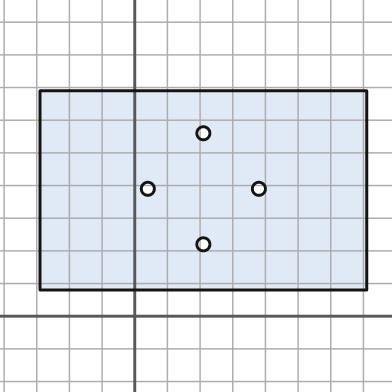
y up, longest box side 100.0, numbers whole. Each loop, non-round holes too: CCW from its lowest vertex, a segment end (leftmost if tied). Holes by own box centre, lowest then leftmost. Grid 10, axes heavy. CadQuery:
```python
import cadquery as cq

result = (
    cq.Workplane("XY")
    .moveTo(-29.0, 8.0)
    .lineTo(71.0, 8.0)
    .lineTo(71.0, 69.0)
    .lineTo(-29.0, 69.0)
    .close()
    .moveTo(21.0, 22.0)
    .circle(2.0)
    .moveTo(4.0, 39.0)
    .circle(2.0)
    .moveTo(38.0, 39.0)
    .circle(2.0)
    .moveTo(21.0, 56.0)
    .circle(2.0)
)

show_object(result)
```